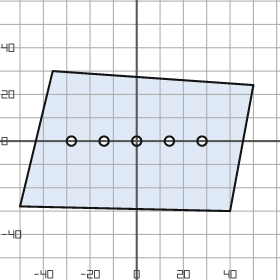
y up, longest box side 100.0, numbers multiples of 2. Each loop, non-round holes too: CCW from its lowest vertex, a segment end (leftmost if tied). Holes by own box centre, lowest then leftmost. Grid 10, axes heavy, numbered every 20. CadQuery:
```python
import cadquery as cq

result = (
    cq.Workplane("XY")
    .moveTo(40.0, -30.0)
    .lineTo(50.0, 24.0)
    .lineTo(-36.0, 30.0)
    .lineTo(-50.0, -28.0)
    .close()
    .moveTo(-28.0, 0.0)
    .circle(2.0)
    .moveTo(-14.0, 0.0)
    .circle(2.0)
    .moveTo(0.0, 0.0)
    .circle(2.0)
    .moveTo(14.0, 0.0)
    .circle(2.0)
    .moveTo(28.0, 0.0)
    .circle(2.0)
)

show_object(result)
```